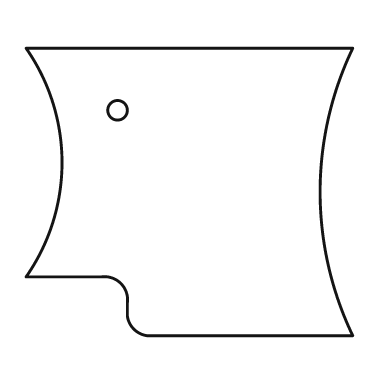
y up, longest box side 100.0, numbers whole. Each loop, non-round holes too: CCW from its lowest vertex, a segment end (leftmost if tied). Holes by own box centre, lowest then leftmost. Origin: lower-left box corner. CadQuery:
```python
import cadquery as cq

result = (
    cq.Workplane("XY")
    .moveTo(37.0, 0.0)
    .lineTo(100.0, 0.0)
    .threePointArc((90.0, 44.0), (100.0, 88.0))
    .lineTo(0.0, 88.0)
    .threePointArc((11.0, 53.0), (0.0, 18.0))
    .lineTo(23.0, 18.0)
    .threePointArc((29.0, 16.0), (31.0, 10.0))
    .lineTo(31.0, 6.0)
    .threePointArc((33.0, 2.0), (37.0, 0.0))
    .close()
    .moveTo(28.0, 69.0)
    .circle(3.0)
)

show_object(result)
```